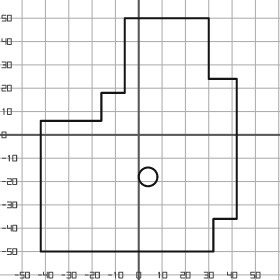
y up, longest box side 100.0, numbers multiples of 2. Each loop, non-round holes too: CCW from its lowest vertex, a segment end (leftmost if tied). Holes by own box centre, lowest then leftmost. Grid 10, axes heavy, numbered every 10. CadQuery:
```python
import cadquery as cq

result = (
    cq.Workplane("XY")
    .moveTo(-42.0, -50.0)
    .lineTo(32.0, -50.0)
    .lineTo(32.0, -36.0)
    .lineTo(42.0, -36.0)
    .lineTo(42.0, 24.0)
    .lineTo(30.0, 24.0)
    .lineTo(30.0, 50.0)
    .lineTo(-6.0, 50.0)
    .lineTo(-6.0, 18.0)
    .lineTo(-16.0, 18.0)
    .lineTo(-16.0, 6.0)
    .lineTo(-42.0, 6.0)
    .close()
    .moveTo(4.0, -18.0)
    .circle(4.0)
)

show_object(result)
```